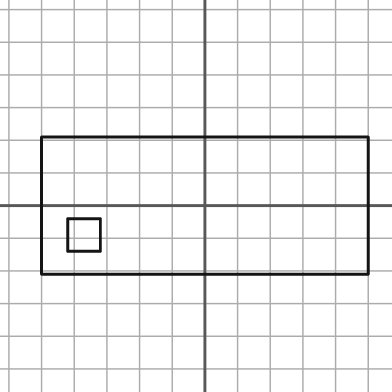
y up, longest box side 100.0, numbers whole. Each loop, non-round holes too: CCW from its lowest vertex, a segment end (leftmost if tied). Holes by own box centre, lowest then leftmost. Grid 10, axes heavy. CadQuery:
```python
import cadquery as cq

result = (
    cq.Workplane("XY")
    .moveTo(-50.0, -21.0)
    .lineTo(50.0, -21.0)
    .lineTo(50.0, 21.0)
    .lineTo(-50.0, 21.0)
    .close()
    .moveTo(-42.0, -14.0)
    .lineTo(-32.0, -14.0)
    .lineTo(-32.0, -4.0)
    .lineTo(-42.0, -4.0)
    .close()
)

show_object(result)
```